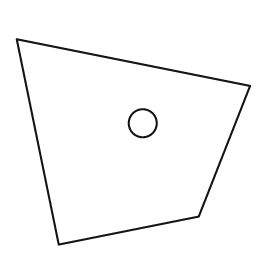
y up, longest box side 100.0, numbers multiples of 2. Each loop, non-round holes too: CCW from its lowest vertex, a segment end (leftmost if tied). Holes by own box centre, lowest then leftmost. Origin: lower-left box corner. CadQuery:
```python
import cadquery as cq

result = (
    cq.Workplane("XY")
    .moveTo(18.0, 0.0)
    .lineTo(78.0, 12.0)
    .lineTo(100.0, 68.0)
    .lineTo(0.0, 88.0)
    .close()
    .moveTo(54.0, 52.0)
    .circle(6.0)
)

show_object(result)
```